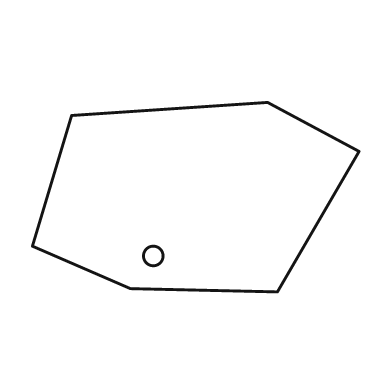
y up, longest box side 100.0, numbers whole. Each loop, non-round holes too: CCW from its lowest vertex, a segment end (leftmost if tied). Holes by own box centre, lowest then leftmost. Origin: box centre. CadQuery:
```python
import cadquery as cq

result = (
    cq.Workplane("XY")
    .moveTo(25.0, -29.0)
    .lineTo(50.0, 14.0)
    .lineTo(22.0, 29.0)
    .lineTo(-38.0, 25.0)
    .lineTo(-50.0, -15.0)
    .lineTo(-20.0, -28.0)
    .close()
    .moveTo(-13.0, -18.0)
    .circle(3.0)
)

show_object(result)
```